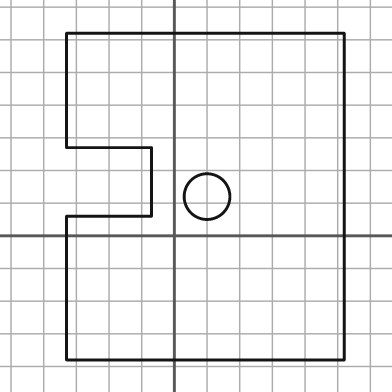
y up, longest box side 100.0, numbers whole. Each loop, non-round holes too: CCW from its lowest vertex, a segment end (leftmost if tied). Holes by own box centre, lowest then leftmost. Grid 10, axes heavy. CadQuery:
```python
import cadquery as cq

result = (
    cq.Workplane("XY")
    .moveTo(-33.0, -38.0)
    .lineTo(52.0, -38.0)
    .lineTo(52.0, 62.0)
    .lineTo(-33.0, 62.0)
    .lineTo(-33.0, 27.0)
    .lineTo(-7.0, 27.0)
    .lineTo(-7.0, 6.0)
    .lineTo(-33.0, 6.0)
    .close()
    .moveTo(10.0, 12.0)
    .circle(7.0)
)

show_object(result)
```